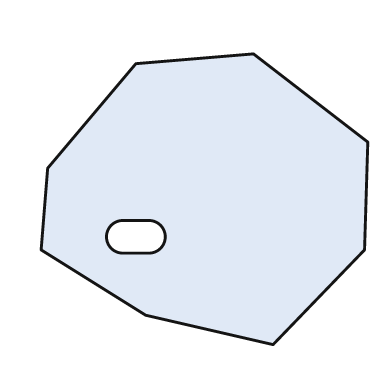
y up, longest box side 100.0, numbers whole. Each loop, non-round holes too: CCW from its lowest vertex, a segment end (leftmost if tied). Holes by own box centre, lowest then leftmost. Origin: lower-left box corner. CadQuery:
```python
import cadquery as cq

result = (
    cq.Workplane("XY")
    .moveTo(71.0, 0.0)
    .lineTo(99.0, 29.0)
    .lineTo(100.0, 62.0)
    .lineTo(65.0, 89.0)
    .lineTo(29.0, 86.0)
    .lineTo(2.0, 54.0)
    .lineTo(0.0, 29.0)
    .lineTo(32.0, 9.0)
    .close()
    .moveTo(25.0, 28.0)
    .lineTo(33.0, 28.0)
    .threePointArc((38.0, 33.0), (33.0, 38.0))
    .lineTo(25.0, 38.0)
    .threePointArc((20.0, 33.0), (25.0, 28.0))
    .close()
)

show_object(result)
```